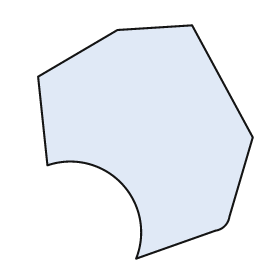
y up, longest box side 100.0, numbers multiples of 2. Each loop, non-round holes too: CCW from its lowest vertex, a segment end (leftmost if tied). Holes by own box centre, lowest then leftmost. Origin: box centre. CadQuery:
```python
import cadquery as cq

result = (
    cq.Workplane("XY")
    .moveTo(-4.0, -50.0)
    .lineTo(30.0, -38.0)
    .threePointArc((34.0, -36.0), (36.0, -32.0))
    .lineTo(46.0, 2.0)
    .lineTo(20.0, 50.0)
    .lineTo(-12.0, 48.0)
    .lineTo(-46.0, 28.0)
    .lineTo(-42.0, -10.0)
    .threePointArc((-10.0, -18.0), (-4.0, -50.0))
    .close()
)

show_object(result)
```